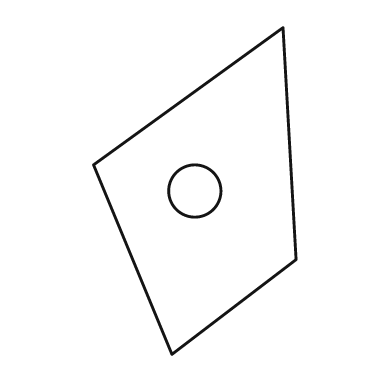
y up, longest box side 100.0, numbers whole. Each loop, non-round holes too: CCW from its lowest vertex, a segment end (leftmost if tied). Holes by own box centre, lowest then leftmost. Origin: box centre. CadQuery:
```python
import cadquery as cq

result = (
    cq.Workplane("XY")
    .moveTo(-7.0, -50.0)
    .lineTo(31.0, -21.0)
    .lineTo(27.0, 50.0)
    .lineTo(-31.0, 8.0)
    .close()
    .moveTo(0.0, 0.0)
    .circle(8.0)
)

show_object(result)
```